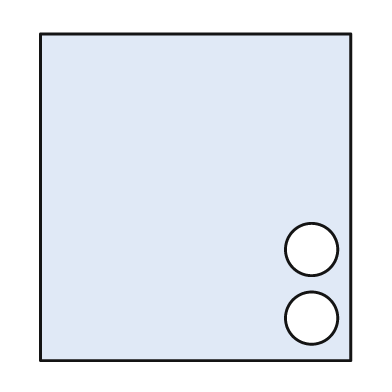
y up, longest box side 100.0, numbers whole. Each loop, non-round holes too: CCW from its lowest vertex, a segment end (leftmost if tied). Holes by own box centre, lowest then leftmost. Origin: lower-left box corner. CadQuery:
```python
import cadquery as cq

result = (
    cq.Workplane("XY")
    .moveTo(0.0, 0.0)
    .lineTo(95.0, 0.0)
    .lineTo(95.0, 100.0)
    .lineTo(0.0, 100.0)
    .close()
    .moveTo(83.0, 13.0)
    .circle(8.0)
    .moveTo(83.0, 34.0)
    .circle(8.0)
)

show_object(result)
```